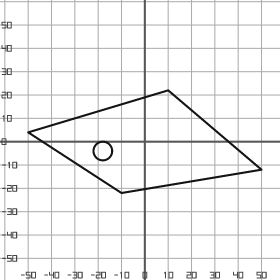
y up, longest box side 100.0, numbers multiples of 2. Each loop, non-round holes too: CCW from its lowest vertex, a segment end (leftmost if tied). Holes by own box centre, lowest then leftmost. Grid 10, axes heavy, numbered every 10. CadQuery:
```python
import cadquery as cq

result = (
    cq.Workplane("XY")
    .moveTo(-10.0, -22.0)
    .lineTo(50.0, -12.0)
    .lineTo(10.0, 22.0)
    .lineTo(-50.0, 4.0)
    .close()
    .moveTo(-18.0, -4.0)
    .circle(4.0)
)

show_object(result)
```